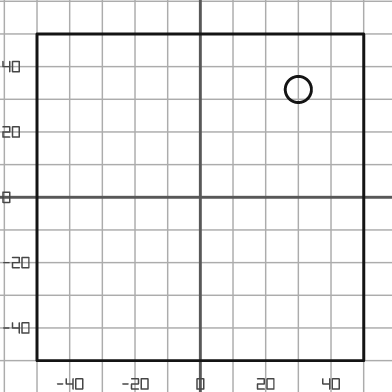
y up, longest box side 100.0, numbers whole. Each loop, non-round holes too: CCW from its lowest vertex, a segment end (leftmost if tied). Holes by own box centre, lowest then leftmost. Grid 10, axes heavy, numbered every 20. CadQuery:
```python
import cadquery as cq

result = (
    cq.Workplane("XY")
    .moveTo(-50.0, -50.0)
    .lineTo(50.0, -50.0)
    .lineTo(50.0, 50.0)
    .lineTo(-50.0, 50.0)
    .close()
    .moveTo(30.0, 33.0)
    .circle(4.0)
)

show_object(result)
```